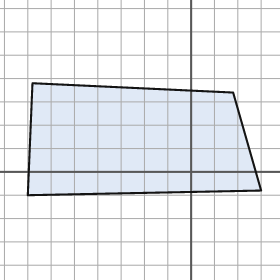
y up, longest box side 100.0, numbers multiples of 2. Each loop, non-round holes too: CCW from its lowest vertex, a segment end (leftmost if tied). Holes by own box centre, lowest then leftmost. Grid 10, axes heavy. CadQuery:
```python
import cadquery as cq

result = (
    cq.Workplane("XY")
    .moveTo(-70.0, -10.0)
    .lineTo(30.0, -8.0)
    .lineTo(18.0, 34.0)
    .lineTo(-68.0, 38.0)
    .close()
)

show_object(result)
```